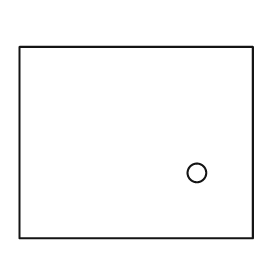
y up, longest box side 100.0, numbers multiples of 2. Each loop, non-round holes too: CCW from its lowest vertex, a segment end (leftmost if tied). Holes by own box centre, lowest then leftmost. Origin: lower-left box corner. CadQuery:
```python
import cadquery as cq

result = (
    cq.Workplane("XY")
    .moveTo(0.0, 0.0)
    .lineTo(100.0, 0.0)
    .lineTo(100.0, 82.0)
    .lineTo(0.0, 82.0)
    .close()
    .moveTo(76.0, 28.0)
    .circle(4.0)
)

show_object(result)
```